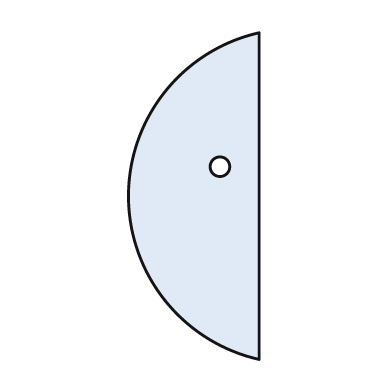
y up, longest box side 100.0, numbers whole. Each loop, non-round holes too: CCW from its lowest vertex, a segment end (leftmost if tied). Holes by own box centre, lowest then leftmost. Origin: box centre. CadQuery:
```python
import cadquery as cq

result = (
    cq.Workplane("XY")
    .moveTo(20.0, -50.0)
    .lineTo(20.0, 50.0)
    .threePointArc((-20.0, 0.0), (20.0, -50.0))
    .close()
    .moveTo(8.0, 9.0)
    .circle(3.0)
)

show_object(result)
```